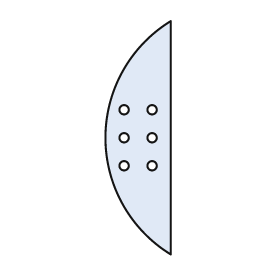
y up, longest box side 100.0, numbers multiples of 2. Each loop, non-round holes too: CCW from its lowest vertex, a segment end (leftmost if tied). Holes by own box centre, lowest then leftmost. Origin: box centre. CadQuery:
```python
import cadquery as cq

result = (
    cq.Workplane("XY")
    .moveTo(14.0, -50.0)
    .lineTo(14.0, 50.0)
    .threePointArc((-14.0, 0.0), (14.0, -50.0))
    .close()
    .moveTo(-6.0, -12.0)
    .circle(2.0)
    .moveTo(6.0, -12.0)
    .circle(2.0)
    .moveTo(-6.0, 0.0)
    .circle(2.0)
    .moveTo(6.0, 0.0)
    .circle(2.0)
    .moveTo(-6.0, 12.0)
    .circle(2.0)
    .moveTo(6.0, 12.0)
    .circle(2.0)
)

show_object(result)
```